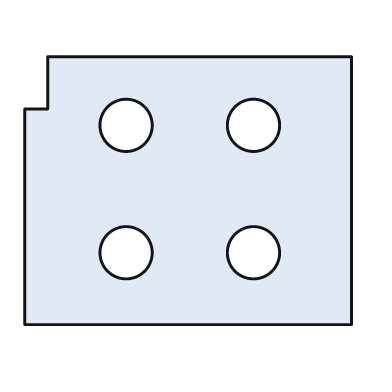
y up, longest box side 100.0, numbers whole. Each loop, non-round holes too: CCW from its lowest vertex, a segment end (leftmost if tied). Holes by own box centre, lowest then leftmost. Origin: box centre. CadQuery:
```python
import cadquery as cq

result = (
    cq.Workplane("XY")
    .moveTo(-50.0, -41.0)
    .lineTo(50.0, -41.0)
    .lineTo(50.0, 41.0)
    .lineTo(-43.0, 41.0)
    .lineTo(-43.0, 25.0)
    .lineTo(-50.0, 25.0)
    .close()
    .moveTo(-19.0, -19.0)
    .circle(8.0)
    .moveTo(20.0, -19.0)
    .circle(8.0)
    .moveTo(-19.0, 20.0)
    .circle(8.0)
    .moveTo(20.0, 20.0)
    .circle(8.0)
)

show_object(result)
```